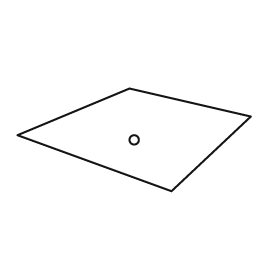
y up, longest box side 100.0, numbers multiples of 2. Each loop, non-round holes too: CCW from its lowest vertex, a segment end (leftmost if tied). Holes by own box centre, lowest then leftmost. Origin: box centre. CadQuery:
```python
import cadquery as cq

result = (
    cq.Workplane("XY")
    .moveTo(16.0, -22.0)
    .lineTo(50.0, 10.0)
    .lineTo(-2.0, 22.0)
    .lineTo(-50.0, 2.0)
    .close()
    .moveTo(0.0, 0.0)
    .circle(2.0)
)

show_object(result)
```